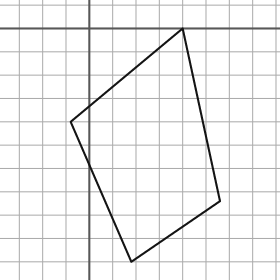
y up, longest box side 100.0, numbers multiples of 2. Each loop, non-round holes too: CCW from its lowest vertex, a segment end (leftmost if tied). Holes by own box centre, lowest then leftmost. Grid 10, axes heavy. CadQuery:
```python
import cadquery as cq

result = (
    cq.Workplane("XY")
    .moveTo(18.0, -100.0)
    .lineTo(56.0, -74.0)
    .lineTo(40.0, 0.0)
    .lineTo(-8.0, -40.0)
    .close()
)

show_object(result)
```